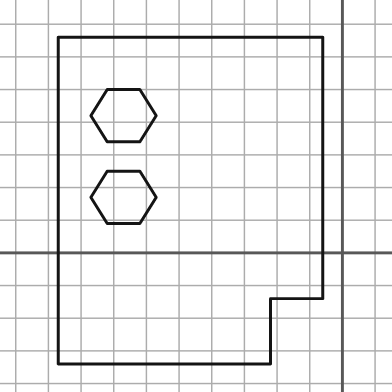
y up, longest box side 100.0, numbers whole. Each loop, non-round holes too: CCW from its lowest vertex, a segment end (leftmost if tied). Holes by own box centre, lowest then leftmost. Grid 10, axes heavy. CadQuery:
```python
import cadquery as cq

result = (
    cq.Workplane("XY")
    .moveTo(-87.0, -34.0)
    .lineTo(-22.0, -34.0)
    .lineTo(-22.0, -14.0)
    .lineTo(-6.0, -14.0)
    .lineTo(-6.0, 66.0)
    .lineTo(-87.0, 66.0)
    .close()
    .moveTo(-72.0, 9.0)
    .lineTo(-62.0, 9.0)
    .lineTo(-57.0, 17.0)
    .lineTo(-62.0, 25.0)
    .lineTo(-72.0, 25.0)
    .lineTo(-77.0, 17.0)
    .close()
    .moveTo(-72.0, 34.0)
    .lineTo(-62.0, 34.0)
    .lineTo(-57.0, 42.0)
    .lineTo(-62.0, 50.0)
    .lineTo(-72.0, 50.0)
    .lineTo(-77.0, 42.0)
    .close()
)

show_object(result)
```